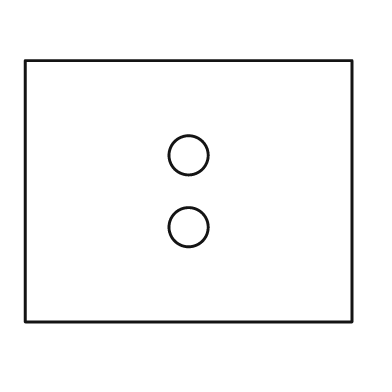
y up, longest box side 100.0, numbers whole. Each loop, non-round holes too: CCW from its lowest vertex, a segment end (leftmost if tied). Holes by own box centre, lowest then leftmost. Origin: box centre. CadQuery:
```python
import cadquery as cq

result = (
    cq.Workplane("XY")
    .moveTo(-50.0, -40.0)
    .lineTo(50.0, -40.0)
    .lineTo(50.0, 40.0)
    .lineTo(-50.0, 40.0)
    .close()
    .moveTo(0.0, -11.0)
    .circle(6.0)
    .moveTo(0.0, 11.0)
    .circle(6.0)
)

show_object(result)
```